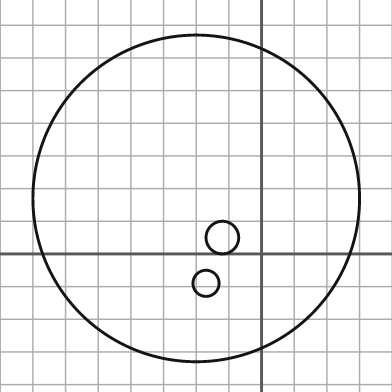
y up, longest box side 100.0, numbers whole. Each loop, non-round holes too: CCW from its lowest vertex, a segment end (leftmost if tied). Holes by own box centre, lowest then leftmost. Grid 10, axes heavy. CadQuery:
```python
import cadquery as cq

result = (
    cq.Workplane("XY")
    .moveTo(-20.0, 17.0)
    .circle(50.0)
    .moveTo(-17.0, -9.0)
    .circle(4.0)
    .moveTo(-12.0, 5.0)
    .circle(5.0)
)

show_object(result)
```